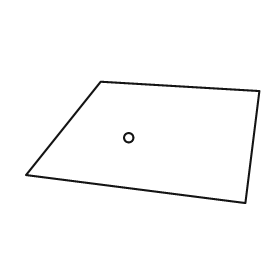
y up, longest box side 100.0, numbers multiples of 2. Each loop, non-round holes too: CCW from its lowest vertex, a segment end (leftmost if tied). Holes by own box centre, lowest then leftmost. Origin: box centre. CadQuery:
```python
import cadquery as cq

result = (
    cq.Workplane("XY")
    .moveTo(44.0, -26.0)
    .lineTo(50.0, 22.0)
    .lineTo(-18.0, 26.0)
    .lineTo(-50.0, -14.0)
    .close()
    .moveTo(-6.0, 2.0)
    .circle(2.0)
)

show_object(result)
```